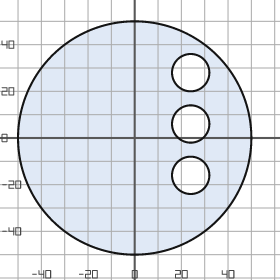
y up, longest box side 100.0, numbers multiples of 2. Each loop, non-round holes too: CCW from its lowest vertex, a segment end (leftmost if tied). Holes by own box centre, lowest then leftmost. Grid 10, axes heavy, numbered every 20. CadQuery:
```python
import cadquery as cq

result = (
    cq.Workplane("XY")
    .moveTo(0.0, 0.0)
    .circle(50.0)
    .moveTo(24.0, -16.0)
    .circle(8.0)
    .moveTo(24.0, 6.0)
    .circle(8.0)
    .moveTo(24.0, 28.0)
    .circle(8.0)
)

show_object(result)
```